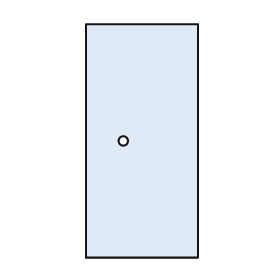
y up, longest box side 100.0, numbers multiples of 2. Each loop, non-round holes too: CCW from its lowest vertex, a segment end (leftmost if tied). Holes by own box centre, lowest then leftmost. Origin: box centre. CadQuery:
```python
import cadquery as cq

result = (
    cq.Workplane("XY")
    .moveTo(-24.0, -50.0)
    .lineTo(24.0, -50.0)
    .lineTo(24.0, 50.0)
    .lineTo(-24.0, 50.0)
    .close()
    .moveTo(-8.0, 0.0)
    .circle(2.0)
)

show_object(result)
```